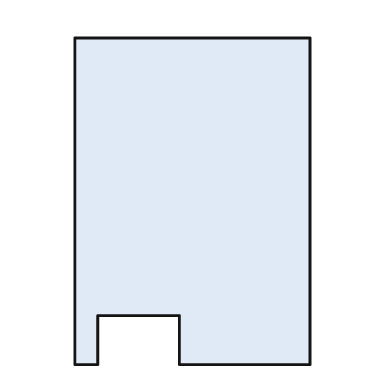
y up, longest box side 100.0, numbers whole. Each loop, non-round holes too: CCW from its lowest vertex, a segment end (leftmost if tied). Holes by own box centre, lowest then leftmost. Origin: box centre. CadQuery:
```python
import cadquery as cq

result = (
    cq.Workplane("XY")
    .moveTo(-36.0, -50.0)
    .lineTo(-29.0, -50.0)
    .lineTo(-29.0, -35.0)
    .lineTo(-4.0, -35.0)
    .lineTo(-4.0, -50.0)
    .lineTo(36.0, -50.0)
    .lineTo(36.0, 50.0)
    .lineTo(-36.0, 50.0)
    .close()
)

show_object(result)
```